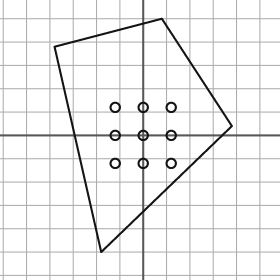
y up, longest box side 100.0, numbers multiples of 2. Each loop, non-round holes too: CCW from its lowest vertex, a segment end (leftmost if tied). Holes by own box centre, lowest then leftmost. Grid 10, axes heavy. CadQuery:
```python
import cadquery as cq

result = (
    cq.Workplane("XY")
    .moveTo(-18.0, -50.0)
    .lineTo(38.0, 4.0)
    .lineTo(8.0, 50.0)
    .lineTo(-38.0, 38.0)
    .close()
    .moveTo(-12.0, -12.0)
    .circle(2.0)
    .moveTo(0.0, -12.0)
    .circle(2.0)
    .moveTo(12.0, -12.0)
    .circle(2.0)
    .moveTo(-12.0, 0.0)
    .circle(2.0)
    .moveTo(0.0, 0.0)
    .circle(2.0)
    .moveTo(12.0, 0.0)
    .circle(2.0)
    .moveTo(-12.0, 12.0)
    .circle(2.0)
    .moveTo(0.0, 12.0)
    .circle(2.0)
    .moveTo(12.0, 12.0)
    .circle(2.0)
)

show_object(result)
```